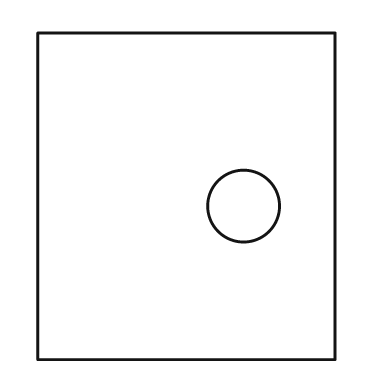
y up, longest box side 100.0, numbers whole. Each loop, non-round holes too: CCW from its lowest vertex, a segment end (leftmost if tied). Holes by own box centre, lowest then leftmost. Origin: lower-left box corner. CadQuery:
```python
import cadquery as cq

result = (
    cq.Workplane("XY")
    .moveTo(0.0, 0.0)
    .lineTo(91.0, 0.0)
    .lineTo(91.0, 100.0)
    .lineTo(0.0, 100.0)
    .close()
    .moveTo(63.0, 47.0)
    .circle(11.0)
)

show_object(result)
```